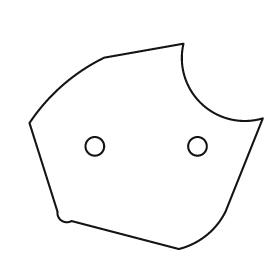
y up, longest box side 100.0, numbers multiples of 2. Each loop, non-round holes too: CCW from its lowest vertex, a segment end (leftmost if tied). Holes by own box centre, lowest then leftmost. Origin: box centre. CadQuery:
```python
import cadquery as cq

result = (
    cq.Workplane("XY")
    .moveTo(14.0, -44.0)
    .threePointArc((26.0, -38.0), (34.0, -28.0))
    .lineTo(50.0, 12.0)
    .threePointArc((24.0, 18.0), (16.0, 44.0))
    .lineTo(-18.0, 38.0)
    .threePointArc((-36.0, 26.0), (-50.0, 10.0))
    .lineTo(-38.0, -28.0)
    .threePointArc((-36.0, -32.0), (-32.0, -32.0))
    .close()
    .moveTo(-22.0, 0.0)
    .circle(4.0)
    .moveTo(22.0, 0.0)
    .circle(4.0)
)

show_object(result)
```